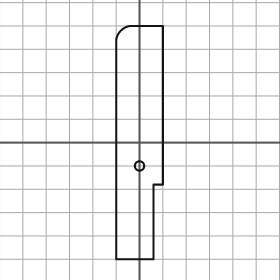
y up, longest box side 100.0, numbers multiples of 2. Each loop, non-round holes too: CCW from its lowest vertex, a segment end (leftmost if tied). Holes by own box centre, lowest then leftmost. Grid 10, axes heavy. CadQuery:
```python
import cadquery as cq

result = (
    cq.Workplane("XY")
    .moveTo(-10.0, -50.0)
    .lineTo(6.0, -50.0)
    .lineTo(6.0, -18.0)
    .lineTo(10.0, -18.0)
    .lineTo(10.0, 50.0)
    .lineTo(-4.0, 50.0)
    .threePointArc((-8.0, 48.0), (-10.0, 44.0))
    .close()
    .moveTo(0.0, -10.0)
    .circle(2.0)
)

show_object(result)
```